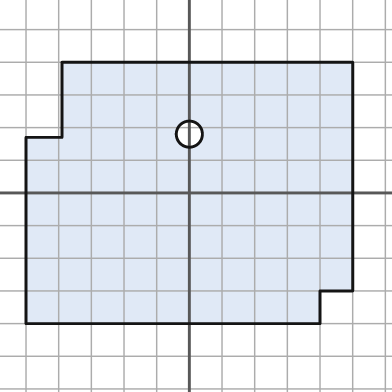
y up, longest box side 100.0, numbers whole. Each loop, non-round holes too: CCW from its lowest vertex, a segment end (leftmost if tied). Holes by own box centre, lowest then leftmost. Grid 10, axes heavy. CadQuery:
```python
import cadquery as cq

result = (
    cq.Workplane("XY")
    .moveTo(-50.0, -40.0)
    .lineTo(40.0, -40.0)
    .lineTo(40.0, -30.0)
    .lineTo(50.0, -30.0)
    .lineTo(50.0, 40.0)
    .lineTo(-39.0, 40.0)
    .lineTo(-39.0, 17.0)
    .lineTo(-50.0, 17.0)
    .close()
    .moveTo(0.0, 18.0)
    .circle(4.0)
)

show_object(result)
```